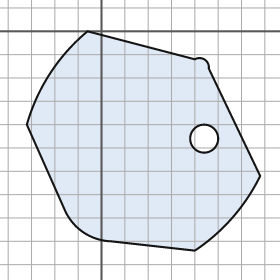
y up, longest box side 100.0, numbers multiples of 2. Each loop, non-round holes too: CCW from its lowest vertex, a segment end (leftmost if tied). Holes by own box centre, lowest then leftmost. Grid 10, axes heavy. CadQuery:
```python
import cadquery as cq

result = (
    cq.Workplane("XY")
    .moveTo(40.0, -94.0)
    .threePointArc((56.0, -80.0), (68.0, -62.0))
    .lineTo(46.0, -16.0)
    .threePointArc((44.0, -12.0), (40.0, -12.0))
    .lineTo(-6.0, 0.0)
    .threePointArc((-22.0, -18.0), (-32.0, -40.0))
    .lineTo(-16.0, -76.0)
    .threePointArc((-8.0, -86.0), (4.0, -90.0))
    .close()
    .moveTo(44.0, -46.0)
    .circle(6.0)
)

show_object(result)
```